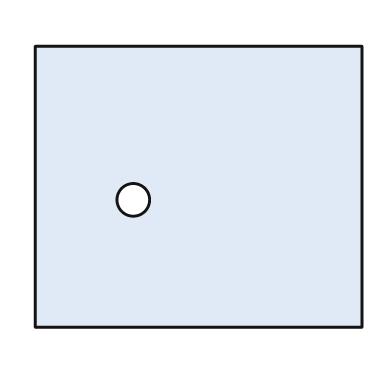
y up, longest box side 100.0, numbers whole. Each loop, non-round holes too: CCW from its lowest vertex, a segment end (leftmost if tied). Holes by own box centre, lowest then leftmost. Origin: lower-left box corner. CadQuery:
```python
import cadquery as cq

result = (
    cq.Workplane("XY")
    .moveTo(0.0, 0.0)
    .lineTo(100.0, 0.0)
    .lineTo(100.0, 86.0)
    .lineTo(0.0, 86.0)
    .close()
    .moveTo(30.0, 39.0)
    .circle(5.0)
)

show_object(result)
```